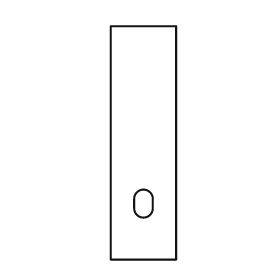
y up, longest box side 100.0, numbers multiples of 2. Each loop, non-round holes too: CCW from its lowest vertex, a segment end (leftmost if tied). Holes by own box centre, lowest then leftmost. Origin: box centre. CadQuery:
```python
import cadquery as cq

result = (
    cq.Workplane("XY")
    .moveTo(-14.0, -50.0)
    .lineTo(14.0, -50.0)
    .lineTo(14.0, 50.0)
    .lineTo(-14.0, 50.0)
    .close()
    .moveTo(-4.0, -28.0)
    .threePointArc((0.0, -32.0), (4.0, -28.0))
    .lineTo(4.0, -24.0)
    .threePointArc((0.0, -20.0), (-4.0, -24.0))
    .close()
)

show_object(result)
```